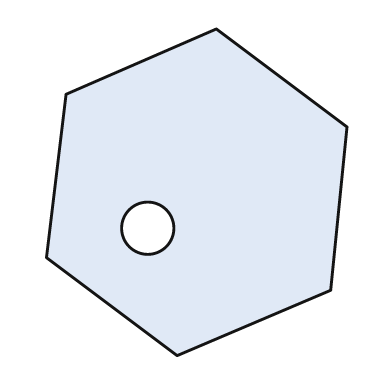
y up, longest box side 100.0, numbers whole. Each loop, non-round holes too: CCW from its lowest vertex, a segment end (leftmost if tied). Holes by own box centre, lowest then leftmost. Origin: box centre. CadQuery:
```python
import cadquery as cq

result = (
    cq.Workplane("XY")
    .moveTo(-6.0, -50.0)
    .lineTo(41.0, -30.0)
    .lineTo(46.0, 20.0)
    .lineTo(6.0, 50.0)
    .lineTo(-40.0, 30.0)
    .lineTo(-46.0, -20.0)
    .close()
    .moveTo(-15.0, -11.0)
    .circle(8.0)
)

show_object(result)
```